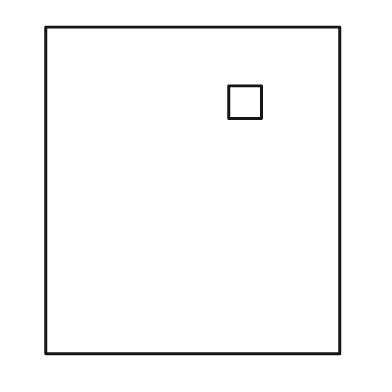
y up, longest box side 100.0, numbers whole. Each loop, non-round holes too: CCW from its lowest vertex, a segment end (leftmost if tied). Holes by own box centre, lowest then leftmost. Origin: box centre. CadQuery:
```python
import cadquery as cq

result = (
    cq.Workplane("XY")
    .moveTo(-45.0, -50.0)
    .lineTo(45.0, -50.0)
    .lineTo(45.0, 50.0)
    .lineTo(-45.0, 50.0)
    .close()
    .moveTo(11.0, 22.0)
    .lineTo(21.0, 22.0)
    .lineTo(21.0, 32.0)
    .lineTo(11.0, 32.0)
    .close()
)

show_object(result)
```